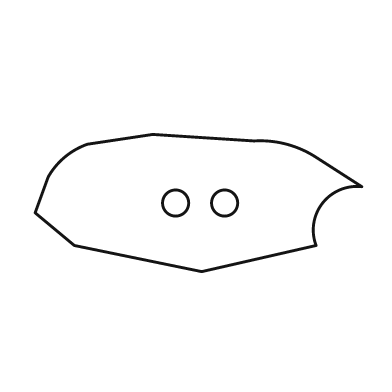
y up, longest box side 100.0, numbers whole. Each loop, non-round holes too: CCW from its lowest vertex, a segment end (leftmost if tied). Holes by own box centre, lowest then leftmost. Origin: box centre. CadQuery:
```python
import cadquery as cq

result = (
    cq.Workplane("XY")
    .moveTo(1.0, -21.0)
    .lineTo(36.0, -13.0)
    .threePointArc((38.0, 0.0), (50.0, 5.0))
    .lineTo(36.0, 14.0)
    .threePointArc((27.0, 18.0), (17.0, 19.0))
    .lineTo(-14.0, 21.0)
    .lineTo(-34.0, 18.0)
    .threePointArc((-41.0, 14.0), (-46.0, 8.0))
    .lineTo(-50.0, -3.0)
    .lineTo(-38.0, -13.0)
    .close()
    .moveTo(-7.0, 0.0)
    .circle(4.0)
    .moveTo(8.0, 0.0)
    .circle(4.0)
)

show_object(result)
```